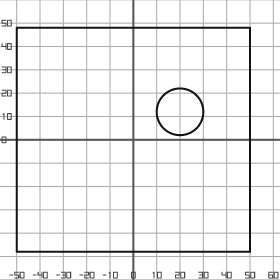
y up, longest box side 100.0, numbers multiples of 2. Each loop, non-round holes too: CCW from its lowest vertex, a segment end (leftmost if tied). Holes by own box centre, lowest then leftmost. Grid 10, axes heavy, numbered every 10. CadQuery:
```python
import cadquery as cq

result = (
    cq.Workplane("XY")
    .moveTo(-50.0, -48.0)
    .lineTo(50.0, -48.0)
    .lineTo(50.0, 48.0)
    .lineTo(-50.0, 48.0)
    .close()
    .moveTo(20.0, 12.0)
    .circle(10.0)
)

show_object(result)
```